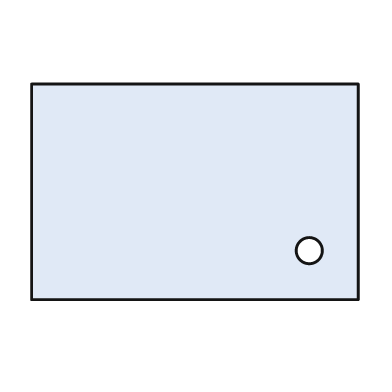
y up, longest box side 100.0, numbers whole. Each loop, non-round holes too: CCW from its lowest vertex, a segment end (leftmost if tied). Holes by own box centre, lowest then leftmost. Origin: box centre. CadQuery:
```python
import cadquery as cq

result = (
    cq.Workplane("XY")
    .moveTo(-50.0, -33.0)
    .lineTo(50.0, -33.0)
    .lineTo(50.0, 33.0)
    .lineTo(-50.0, 33.0)
    .close()
    .moveTo(35.0, -18.0)
    .circle(4.0)
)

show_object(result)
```